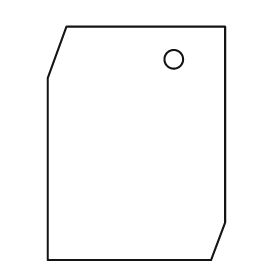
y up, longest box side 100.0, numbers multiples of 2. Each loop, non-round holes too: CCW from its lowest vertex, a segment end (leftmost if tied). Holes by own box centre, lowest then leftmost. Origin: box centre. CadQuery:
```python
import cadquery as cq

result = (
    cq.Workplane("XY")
    .moveTo(-38.0, -50.0)
    .lineTo(32.0, -50.0)
    .lineTo(38.0, -34.0)
    .lineTo(38.0, 50.0)
    .lineTo(-30.0, 50.0)
    .lineTo(-38.0, 28.0)
    .close()
    .moveTo(16.0, 36.0)
    .circle(4.0)
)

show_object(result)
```